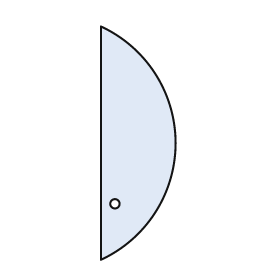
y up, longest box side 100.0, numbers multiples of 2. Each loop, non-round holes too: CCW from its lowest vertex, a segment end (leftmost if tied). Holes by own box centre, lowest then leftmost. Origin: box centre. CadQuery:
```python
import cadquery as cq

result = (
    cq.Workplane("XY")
    .moveTo(-16.0, -50.0)
    .threePointArc((16.0, 0.0), (-16.0, 50.0))
    .close()
    .moveTo(-10.0, -26.0)
    .circle(2.0)
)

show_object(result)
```